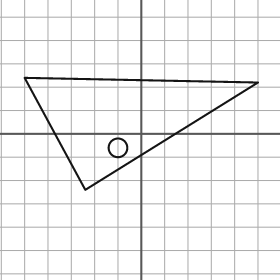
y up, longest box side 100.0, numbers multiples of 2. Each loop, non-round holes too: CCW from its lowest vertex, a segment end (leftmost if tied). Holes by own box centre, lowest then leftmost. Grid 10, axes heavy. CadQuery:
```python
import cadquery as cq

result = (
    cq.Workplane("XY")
    .moveTo(-24.0, -24.0)
    .lineTo(50.0, 22.0)
    .lineTo(-50.0, 24.0)
    .close()
    .moveTo(-10.0, -6.0)
    .circle(4.0)
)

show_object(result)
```